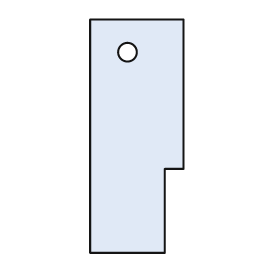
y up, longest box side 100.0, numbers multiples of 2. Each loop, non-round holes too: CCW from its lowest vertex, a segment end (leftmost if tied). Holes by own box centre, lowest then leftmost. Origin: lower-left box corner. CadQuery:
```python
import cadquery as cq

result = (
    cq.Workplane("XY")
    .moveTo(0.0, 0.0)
    .lineTo(32.0, 0.0)
    .lineTo(32.0, 36.0)
    .lineTo(40.0, 36.0)
    .lineTo(40.0, 100.0)
    .lineTo(0.0, 100.0)
    .close()
    .moveTo(16.0, 86.0)
    .circle(4.0)
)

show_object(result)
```